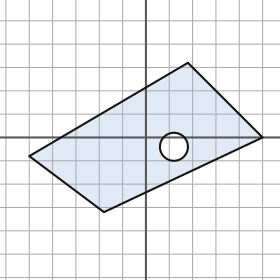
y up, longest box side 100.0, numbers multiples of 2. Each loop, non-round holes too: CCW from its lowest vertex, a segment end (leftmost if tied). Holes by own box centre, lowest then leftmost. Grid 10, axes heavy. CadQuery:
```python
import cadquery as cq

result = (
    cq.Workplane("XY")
    .moveTo(-18.0, -32.0)
    .lineTo(50.0, 0.0)
    .lineTo(18.0, 32.0)
    .lineTo(-50.0, -8.0)
    .close()
    .moveTo(12.0, -4.0)
    .circle(6.0)
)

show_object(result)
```